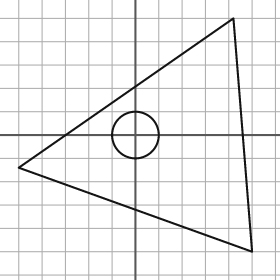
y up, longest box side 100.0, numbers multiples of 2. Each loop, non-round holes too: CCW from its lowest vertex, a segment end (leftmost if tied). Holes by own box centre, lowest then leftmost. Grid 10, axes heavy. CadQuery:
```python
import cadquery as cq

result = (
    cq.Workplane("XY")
    .moveTo(50.0, -50.0)
    .lineTo(42.0, 50.0)
    .lineTo(-50.0, -14.0)
    .close()
    .moveTo(0.0, 0.0)
    .circle(10.0)
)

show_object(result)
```